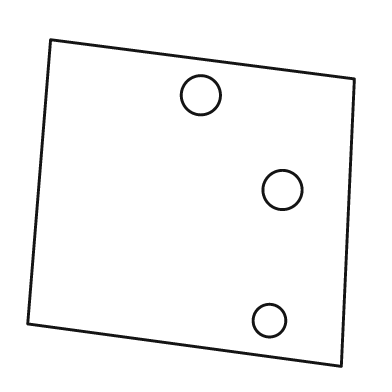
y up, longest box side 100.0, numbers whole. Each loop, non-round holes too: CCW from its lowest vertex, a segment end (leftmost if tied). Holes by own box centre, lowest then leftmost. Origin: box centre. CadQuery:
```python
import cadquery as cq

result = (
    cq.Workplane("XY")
    .moveTo(46.0, -50.0)
    .lineTo(50.0, 38.0)
    .lineTo(-43.0, 50.0)
    .lineTo(-50.0, -37.0)
    .close()
    .moveTo(24.0, -36.0)
    .circle(5.0)
    .moveTo(28.0, 4.0)
    .circle(6.0)
    .moveTo(3.0, 33.0)
    .circle(6.0)
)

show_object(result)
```